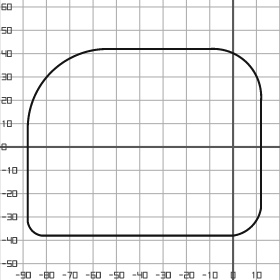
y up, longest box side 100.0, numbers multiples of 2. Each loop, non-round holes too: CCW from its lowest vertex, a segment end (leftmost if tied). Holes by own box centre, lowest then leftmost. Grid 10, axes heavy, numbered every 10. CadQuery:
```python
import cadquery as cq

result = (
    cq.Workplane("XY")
    .moveTo(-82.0, -38.0)
    .lineTo(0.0, -38.0)
    .threePointArc((8.0, -34.0), (12.0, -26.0))
    .lineTo(12.0, 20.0)
    .threePointArc((6.0, 36.0), (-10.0, 42.0))
    .lineTo(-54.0, 42.0)
    .threePointArc((-78.0, 32.0), (-88.0, 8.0))
    .lineTo(-88.0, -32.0)
    .threePointArc((-86.0, -36.0), (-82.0, -38.0))
    .close()
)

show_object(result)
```